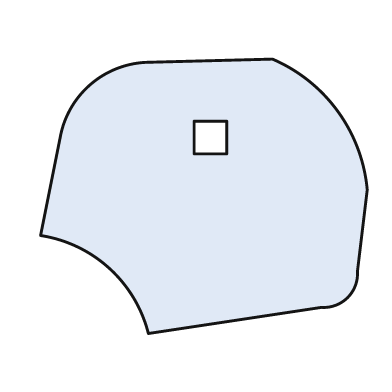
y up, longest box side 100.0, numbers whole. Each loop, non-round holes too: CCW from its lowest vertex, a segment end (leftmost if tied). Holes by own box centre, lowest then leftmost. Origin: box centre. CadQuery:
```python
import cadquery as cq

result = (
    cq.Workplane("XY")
    .moveTo(-17.0, -42.0)
    .lineTo(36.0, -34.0)
    .threePointArc((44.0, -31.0), (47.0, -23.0))
    .lineTo(50.0, 2.0)
    .threePointArc((41.0, 26.0), (21.0, 42.0))
    .lineTo(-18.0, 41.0)
    .threePointArc((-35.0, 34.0), (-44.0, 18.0))
    .lineTo(-50.0, -12.0)
    .threePointArc((-29.0, -22.0), (-17.0, -42.0))
    .close()
    .moveTo(-3.0, 13.0)
    .lineTo(7.0, 13.0)
    .lineTo(7.0, 23.0)
    .lineTo(-3.0, 23.0)
    .close()
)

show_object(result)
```